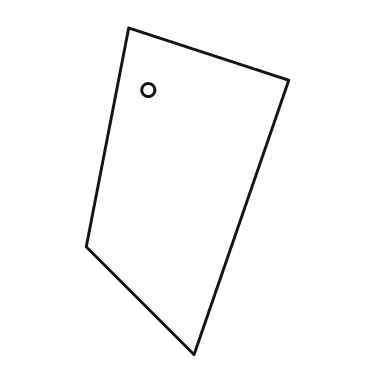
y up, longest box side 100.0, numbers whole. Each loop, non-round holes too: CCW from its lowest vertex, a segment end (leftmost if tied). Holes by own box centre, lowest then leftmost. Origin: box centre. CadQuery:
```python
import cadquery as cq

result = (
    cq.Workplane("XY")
    .moveTo(2.0, -50.0)
    .lineTo(31.0, 34.0)
    .lineTo(-18.0, 50.0)
    .lineTo(-31.0, -17.0)
    .close()
    .moveTo(-12.0, 31.0)
    .circle(2.0)
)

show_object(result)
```